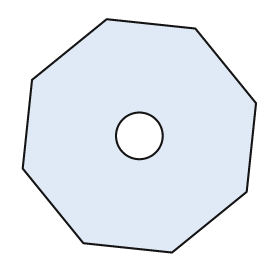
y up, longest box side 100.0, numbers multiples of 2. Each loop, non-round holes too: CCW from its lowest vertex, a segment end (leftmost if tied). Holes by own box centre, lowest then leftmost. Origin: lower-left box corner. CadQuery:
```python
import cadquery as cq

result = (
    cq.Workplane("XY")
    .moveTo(64.0, 0.0)
    .lineTo(96.0, 26.0)
    .lineTo(100.0, 64.0)
    .lineTo(74.0, 96.0)
    .lineTo(36.0, 100.0)
    .lineTo(4.0, 74.0)
    .lineTo(0.0, 36.0)
    .lineTo(26.0, 4.0)
    .close()
    .moveTo(50.0, 50.0)
    .circle(10.0)
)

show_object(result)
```